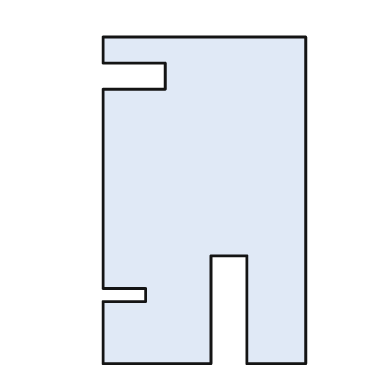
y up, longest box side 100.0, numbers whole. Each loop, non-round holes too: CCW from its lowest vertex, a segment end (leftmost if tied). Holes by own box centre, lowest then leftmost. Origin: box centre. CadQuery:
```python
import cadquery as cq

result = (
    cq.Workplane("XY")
    .moveTo(-31.0, -50.0)
    .lineTo(2.0, -50.0)
    .lineTo(2.0, -17.0)
    .lineTo(13.0, -17.0)
    .lineTo(13.0, -50.0)
    .lineTo(31.0, -50.0)
    .lineTo(31.0, 50.0)
    .lineTo(-31.0, 50.0)
    .lineTo(-31.0, 42.0)
    .lineTo(-12.0, 42.0)
    .lineTo(-12.0, 34.0)
    .lineTo(-31.0, 34.0)
    .lineTo(-31.0, -27.0)
    .lineTo(-18.0, -27.0)
    .lineTo(-18.0, -31.0)
    .lineTo(-31.0, -31.0)
    .close()
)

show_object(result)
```